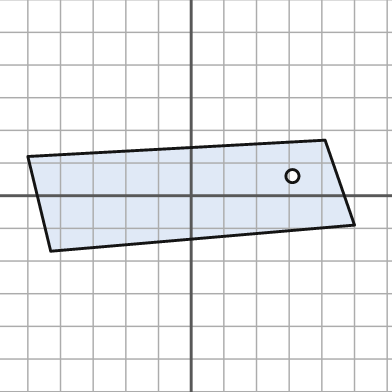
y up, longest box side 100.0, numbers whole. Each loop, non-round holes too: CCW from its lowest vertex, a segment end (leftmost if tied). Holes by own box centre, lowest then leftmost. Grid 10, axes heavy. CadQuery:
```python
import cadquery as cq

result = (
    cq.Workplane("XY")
    .moveTo(-43.0, -17.0)
    .lineTo(50.0, -9.0)
    .lineTo(41.0, 17.0)
    .lineTo(-50.0, 12.0)
    .close()
    .moveTo(31.0, 6.0)
    .circle(2.0)
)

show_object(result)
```